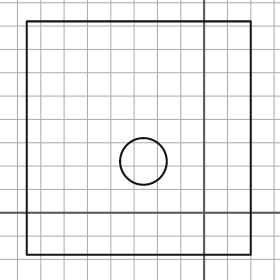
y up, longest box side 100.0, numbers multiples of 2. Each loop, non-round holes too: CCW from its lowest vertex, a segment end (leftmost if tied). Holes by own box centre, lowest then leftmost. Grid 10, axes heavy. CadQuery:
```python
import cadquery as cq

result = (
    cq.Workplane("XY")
    .moveTo(-76.0, -18.0)
    .lineTo(20.0, -18.0)
    .lineTo(20.0, 82.0)
    .lineTo(-76.0, 82.0)
    .close()
    .moveTo(-26.0, 22.0)
    .circle(10.0)
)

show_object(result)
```